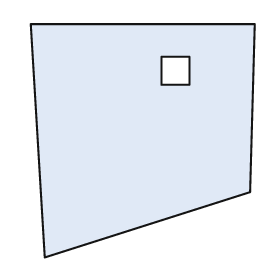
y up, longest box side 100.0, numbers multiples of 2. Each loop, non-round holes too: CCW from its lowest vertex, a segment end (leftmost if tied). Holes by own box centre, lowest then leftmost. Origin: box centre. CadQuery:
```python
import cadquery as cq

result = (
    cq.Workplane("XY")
    .moveTo(-42.0, -50.0)
    .lineTo(46.0, -22.0)
    .lineTo(48.0, 50.0)
    .lineTo(-48.0, 50.0)
    .close()
    .moveTo(8.0, 24.0)
    .lineTo(20.0, 24.0)
    .lineTo(20.0, 36.0)
    .lineTo(8.0, 36.0)
    .close()
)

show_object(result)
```